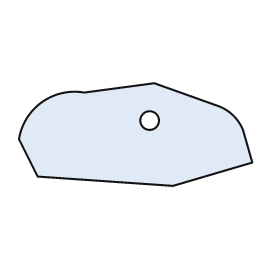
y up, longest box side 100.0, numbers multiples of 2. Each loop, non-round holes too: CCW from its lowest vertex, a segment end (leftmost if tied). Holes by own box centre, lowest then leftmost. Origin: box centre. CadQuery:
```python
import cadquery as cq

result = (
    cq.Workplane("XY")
    .moveTo(16.0, -22.0)
    .lineTo(50.0, -12.0)
    .lineTo(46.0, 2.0)
    .threePointArc((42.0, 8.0), (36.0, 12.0))
    .lineTo(8.0, 22.0)
    .lineTo(-22.0, 18.0)
    .threePointArc((-40.0, 14.0), (-50.0, -2.0))
    .lineTo(-42.0, -18.0)
    .close()
    .moveTo(6.0, 6.0)
    .circle(4.0)
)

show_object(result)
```